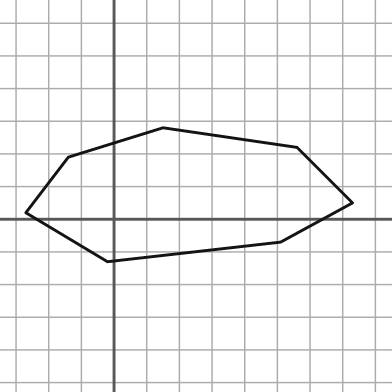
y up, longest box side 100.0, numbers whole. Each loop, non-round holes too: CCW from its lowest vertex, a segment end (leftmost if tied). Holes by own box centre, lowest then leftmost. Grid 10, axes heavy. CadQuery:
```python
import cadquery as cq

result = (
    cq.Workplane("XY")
    .moveTo(-2.0, -13.0)
    .lineTo(51.0, -7.0)
    .lineTo(73.0, 5.0)
    .lineTo(56.0, 22.0)
    .lineTo(15.0, 28.0)
    .lineTo(-14.0, 19.0)
    .lineTo(-27.0, 2.0)
    .close()
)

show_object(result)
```